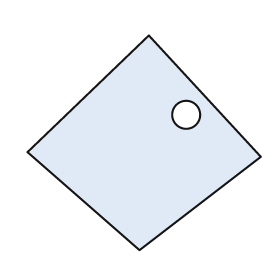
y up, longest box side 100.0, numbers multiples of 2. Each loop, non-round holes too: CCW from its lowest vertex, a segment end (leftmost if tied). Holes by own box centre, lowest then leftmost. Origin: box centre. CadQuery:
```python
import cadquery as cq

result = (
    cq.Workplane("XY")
    .moveTo(-2.0, -46.0)
    .lineTo(50.0, -6.0)
    .lineTo(2.0, 46.0)
    .lineTo(-50.0, -4.0)
    .close()
    .moveTo(18.0, 12.0)
    .circle(6.0)
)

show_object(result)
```